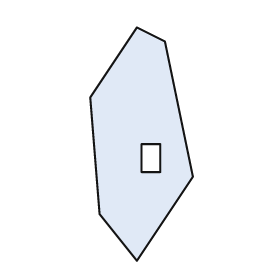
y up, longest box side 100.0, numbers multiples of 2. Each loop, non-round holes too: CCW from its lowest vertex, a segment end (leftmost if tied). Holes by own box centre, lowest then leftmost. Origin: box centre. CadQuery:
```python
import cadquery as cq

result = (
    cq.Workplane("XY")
    .moveTo(-2.0, -50.0)
    .lineTo(22.0, -14.0)
    .lineTo(10.0, 44.0)
    .lineTo(-2.0, 50.0)
    .lineTo(-22.0, 20.0)
    .lineTo(-18.0, -30.0)
    .close()
    .moveTo(0.0, -12.0)
    .lineTo(8.0, -12.0)
    .lineTo(8.0, 0.0)
    .lineTo(0.0, 0.0)
    .close()
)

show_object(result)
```